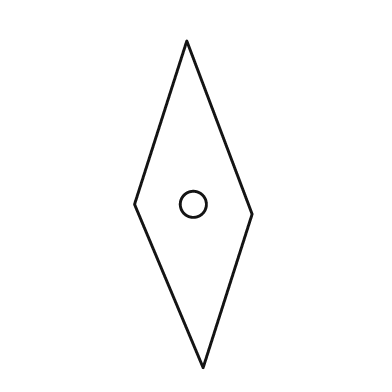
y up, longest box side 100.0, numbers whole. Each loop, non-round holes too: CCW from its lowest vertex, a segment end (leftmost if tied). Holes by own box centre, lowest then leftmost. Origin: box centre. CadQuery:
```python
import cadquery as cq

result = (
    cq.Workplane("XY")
    .moveTo(3.0, -50.0)
    .lineTo(18.0, -3.0)
    .lineTo(-2.0, 50.0)
    .lineTo(-18.0, 0.0)
    .close()
    .moveTo(0.0, 0.0)
    .circle(4.0)
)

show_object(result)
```